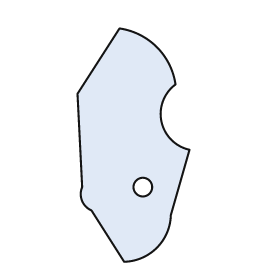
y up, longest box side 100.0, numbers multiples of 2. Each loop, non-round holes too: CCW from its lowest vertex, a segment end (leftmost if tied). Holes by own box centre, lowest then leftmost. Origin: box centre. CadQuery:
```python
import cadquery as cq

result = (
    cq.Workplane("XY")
    .moveTo(-4.0, -50.0)
    .threePointArc((10.0, -44.0), (16.0, -30.0))
    .lineTo(24.0, -2.0)
    .threePointArc((12.0, 10.0), (18.0, 26.0))
    .threePointArc((10.0, 42.0), (-6.0, 50.0))
    .lineTo(-24.0, 22.0)
    .lineTo(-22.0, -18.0)
    .threePointArc((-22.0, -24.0), (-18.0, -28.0))
    .close()
    .moveTo(4.0, -18.0)
    .circle(4.0)
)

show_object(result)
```